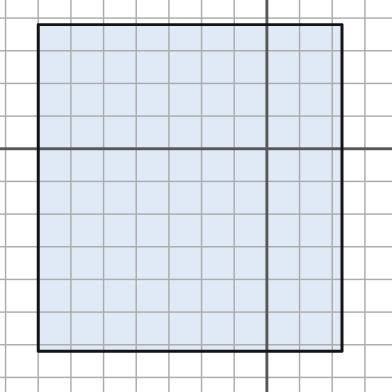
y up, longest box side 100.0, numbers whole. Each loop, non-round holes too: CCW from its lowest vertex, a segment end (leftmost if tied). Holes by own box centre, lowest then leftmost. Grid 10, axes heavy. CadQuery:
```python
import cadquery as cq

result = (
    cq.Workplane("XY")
    .moveTo(-70.0, -62.0)
    .lineTo(23.0, -62.0)
    .lineTo(23.0, 38.0)
    .lineTo(-70.0, 38.0)
    .close()
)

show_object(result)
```